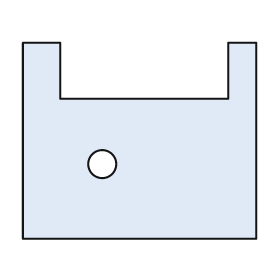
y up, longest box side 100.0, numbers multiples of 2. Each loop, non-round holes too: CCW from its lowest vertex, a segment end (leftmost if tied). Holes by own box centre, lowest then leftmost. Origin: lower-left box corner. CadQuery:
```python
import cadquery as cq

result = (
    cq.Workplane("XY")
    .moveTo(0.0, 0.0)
    .lineTo(100.0, 0.0)
    .lineTo(100.0, 84.0)
    .lineTo(88.0, 84.0)
    .lineTo(88.0, 60.0)
    .lineTo(16.0, 60.0)
    .lineTo(16.0, 84.0)
    .lineTo(0.0, 84.0)
    .close()
    .moveTo(34.0, 32.0)
    .circle(6.0)
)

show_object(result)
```